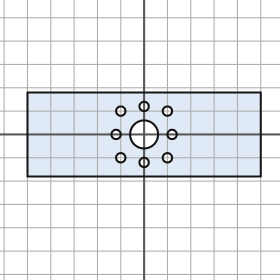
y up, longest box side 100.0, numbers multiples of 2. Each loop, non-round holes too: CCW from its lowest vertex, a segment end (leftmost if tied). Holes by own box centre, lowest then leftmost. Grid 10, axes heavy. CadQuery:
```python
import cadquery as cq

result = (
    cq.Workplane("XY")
    .moveTo(-50.0, -18.0)
    .lineTo(50.0, -18.0)
    .lineTo(50.0, 18.0)
    .lineTo(-50.0, 18.0)
    .close()
    .moveTo(0.0, -12.0)
    .circle(2.0)
    .moveTo(-10.0, -10.0)
    .circle(2.0)
    .moveTo(10.0, -10.0)
    .circle(2.0)
    .moveTo(-12.0, 0.0)
    .circle(2.0)
    .moveTo(0.0, 0.0)
    .circle(6.0)
    .moveTo(12.0, 0.0)
    .circle(2.0)
    .moveTo(-10.0, 10.0)
    .circle(2.0)
    .moveTo(10.0, 10.0)
    .circle(2.0)
    .moveTo(0.0, 12.0)
    .circle(2.0)
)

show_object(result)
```